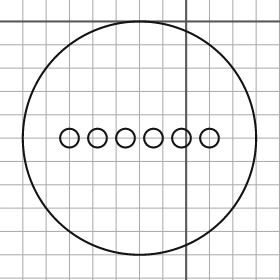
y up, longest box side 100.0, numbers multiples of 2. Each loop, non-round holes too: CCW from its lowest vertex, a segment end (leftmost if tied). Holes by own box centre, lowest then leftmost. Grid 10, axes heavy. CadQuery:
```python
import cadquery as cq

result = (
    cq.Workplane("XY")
    .moveTo(-20.0, -50.0)
    .circle(50.0)
    .moveTo(-50.0, -50.0)
    .circle(4.0)
    .moveTo(-38.0, -50.0)
    .circle(4.0)
    .moveTo(-26.0, -50.0)
    .circle(4.0)
    .moveTo(-14.0, -50.0)
    .circle(4.0)
    .moveTo(-2.0, -50.0)
    .circle(4.0)
    .moveTo(10.0, -50.0)
    .circle(4.0)
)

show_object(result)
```